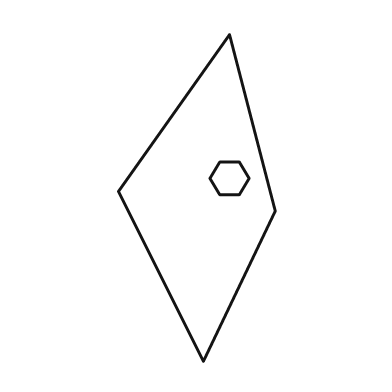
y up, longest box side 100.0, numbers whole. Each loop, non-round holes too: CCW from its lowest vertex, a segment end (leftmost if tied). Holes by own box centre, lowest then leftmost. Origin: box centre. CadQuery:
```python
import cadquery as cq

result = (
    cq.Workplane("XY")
    .moveTo(2.0, -50.0)
    .lineTo(24.0, -4.0)
    .lineTo(10.0, 50.0)
    .lineTo(-24.0, 2.0)
    .close()
    .moveTo(7.0, 1.0)
    .lineTo(13.0, 1.0)
    .lineTo(16.0, 6.0)
    .lineTo(13.0, 11.0)
    .lineTo(7.0, 11.0)
    .lineTo(4.0, 6.0)
    .close()
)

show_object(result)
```